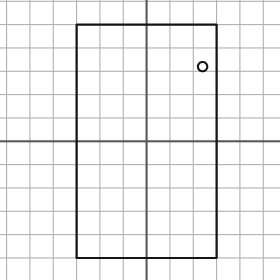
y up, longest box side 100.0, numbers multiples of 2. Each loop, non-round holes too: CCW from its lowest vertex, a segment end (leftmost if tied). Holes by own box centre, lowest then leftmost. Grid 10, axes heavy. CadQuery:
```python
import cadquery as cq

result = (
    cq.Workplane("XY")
    .moveTo(-30.0, -50.0)
    .lineTo(30.0, -50.0)
    .lineTo(30.0, 50.0)
    .lineTo(-30.0, 50.0)
    .close()
    .moveTo(24.0, 32.0)
    .circle(2.0)
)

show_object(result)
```